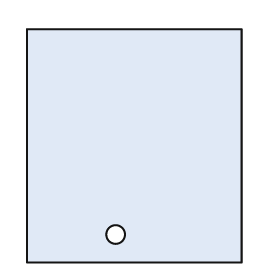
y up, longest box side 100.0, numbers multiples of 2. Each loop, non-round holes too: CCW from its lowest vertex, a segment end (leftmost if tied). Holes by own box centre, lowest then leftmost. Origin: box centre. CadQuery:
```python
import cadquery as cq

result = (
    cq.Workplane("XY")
    .moveTo(-46.0, -50.0)
    .lineTo(46.0, -50.0)
    .lineTo(46.0, 50.0)
    .lineTo(-46.0, 50.0)
    .close()
    .moveTo(-8.0, -38.0)
    .circle(4.0)
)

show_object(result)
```